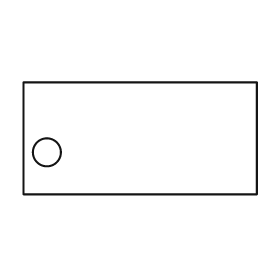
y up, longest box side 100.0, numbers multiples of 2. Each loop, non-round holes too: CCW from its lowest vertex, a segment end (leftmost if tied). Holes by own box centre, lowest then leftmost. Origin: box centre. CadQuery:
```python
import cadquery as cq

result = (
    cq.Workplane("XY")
    .moveTo(-50.0, -24.0)
    .lineTo(50.0, -24.0)
    .lineTo(50.0, 24.0)
    .lineTo(-50.0, 24.0)
    .close()
    .moveTo(-40.0, -6.0)
    .circle(6.0)
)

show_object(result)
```